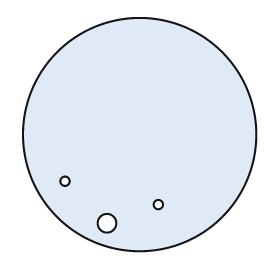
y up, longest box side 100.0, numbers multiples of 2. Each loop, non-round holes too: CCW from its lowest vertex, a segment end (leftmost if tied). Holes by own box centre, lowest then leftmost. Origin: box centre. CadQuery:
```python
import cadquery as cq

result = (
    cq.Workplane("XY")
    .moveTo(0.0, 0.0)
    .circle(50.0)
    .moveTo(-14.0, -38.0)
    .circle(4.0)
    .moveTo(8.0, -30.0)
    .circle(2.0)
    .moveTo(-32.0, -20.0)
    .circle(2.0)
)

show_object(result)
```